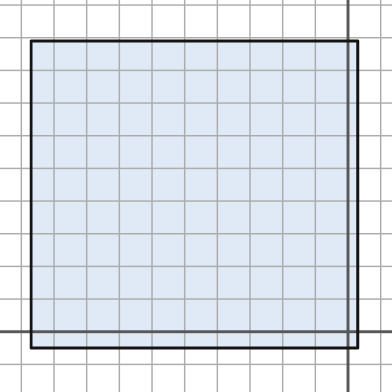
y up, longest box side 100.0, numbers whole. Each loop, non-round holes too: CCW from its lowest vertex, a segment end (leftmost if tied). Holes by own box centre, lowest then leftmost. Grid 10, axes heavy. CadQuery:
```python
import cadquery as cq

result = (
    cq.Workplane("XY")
    .moveTo(-97.0, -5.0)
    .lineTo(3.0, -5.0)
    .lineTo(3.0, 89.0)
    .lineTo(-97.0, 89.0)
    .close()
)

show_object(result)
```